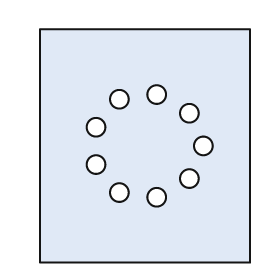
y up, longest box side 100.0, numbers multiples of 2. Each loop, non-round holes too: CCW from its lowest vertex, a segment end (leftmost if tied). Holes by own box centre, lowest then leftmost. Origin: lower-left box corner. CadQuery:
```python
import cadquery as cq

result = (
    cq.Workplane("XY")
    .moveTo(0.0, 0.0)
    .lineTo(90.0, 0.0)
    .lineTo(90.0, 100.0)
    .lineTo(0.0, 100.0)
    .close()
    .moveTo(50.0, 28.0)
    .circle(4.0)
    .moveTo(34.0, 30.0)
    .circle(4.0)
    .moveTo(64.0, 36.0)
    .circle(4.0)
    .moveTo(24.0, 42.0)
    .circle(4.0)
    .moveTo(70.0, 50.0)
    .circle(4.0)
    .moveTo(24.0, 58.0)
    .circle(4.0)
    .moveTo(64.0, 64.0)
    .circle(4.0)
    .moveTo(34.0, 70.0)
    .circle(4.0)
    .moveTo(50.0, 72.0)
    .circle(4.0)
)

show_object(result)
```